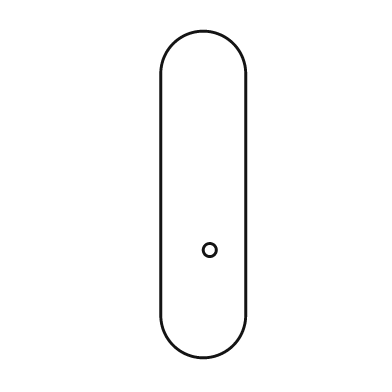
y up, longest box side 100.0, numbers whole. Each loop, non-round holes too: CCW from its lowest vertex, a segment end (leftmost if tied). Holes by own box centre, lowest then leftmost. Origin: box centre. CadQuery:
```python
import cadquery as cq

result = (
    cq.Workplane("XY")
    .moveTo(-13.0, -37.0)
    .threePointArc((0.0, -50.0), (13.0, -37.0))
    .lineTo(13.0, 37.0)
    .threePointArc((0.0, 50.0), (-13.0, 37.0))
    .close()
    .moveTo(2.0, -17.0)
    .circle(2.0)
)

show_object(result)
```